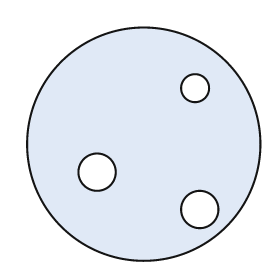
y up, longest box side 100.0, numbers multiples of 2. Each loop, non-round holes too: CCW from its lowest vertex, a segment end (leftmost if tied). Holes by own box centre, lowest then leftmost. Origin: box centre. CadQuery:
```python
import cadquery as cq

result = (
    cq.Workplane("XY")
    .moveTo(0.0, 0.0)
    .circle(50.0)
    .moveTo(24.0, -28.0)
    .circle(8.0)
    .moveTo(-20.0, -12.0)
    .circle(8.0)
    .moveTo(22.0, 24.0)
    .circle(6.0)
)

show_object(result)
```